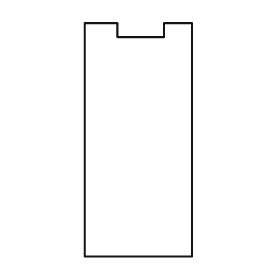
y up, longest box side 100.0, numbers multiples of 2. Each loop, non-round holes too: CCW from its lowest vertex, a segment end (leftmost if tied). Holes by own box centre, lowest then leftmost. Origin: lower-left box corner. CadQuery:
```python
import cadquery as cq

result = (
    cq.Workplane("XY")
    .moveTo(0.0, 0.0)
    .lineTo(46.0, 0.0)
    .lineTo(46.0, 100.0)
    .lineTo(34.0, 100.0)
    .lineTo(34.0, 94.0)
    .lineTo(14.0, 94.0)
    .lineTo(14.0, 100.0)
    .lineTo(0.0, 100.0)
    .close()
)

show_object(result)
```